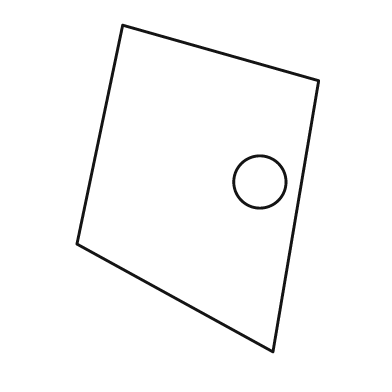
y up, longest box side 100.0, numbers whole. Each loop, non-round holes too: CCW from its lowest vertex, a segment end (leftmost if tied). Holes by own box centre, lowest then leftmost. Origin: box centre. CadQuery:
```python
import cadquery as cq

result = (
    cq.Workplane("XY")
    .moveTo(23.0, -50.0)
    .lineTo(37.0, 33.0)
    .lineTo(-23.0, 50.0)
    .lineTo(-37.0, -17.0)
    .close()
    .moveTo(19.0, 2.0)
    .circle(8.0)
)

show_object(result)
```